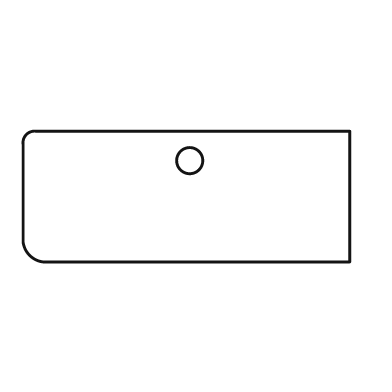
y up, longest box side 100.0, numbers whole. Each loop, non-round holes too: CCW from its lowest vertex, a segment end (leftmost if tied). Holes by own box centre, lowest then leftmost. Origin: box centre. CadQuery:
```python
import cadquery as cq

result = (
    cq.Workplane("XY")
    .moveTo(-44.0, -20.0)
    .lineTo(50.0, -20.0)
    .lineTo(50.0, 20.0)
    .lineTo(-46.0, 20.0)
    .threePointArc((-49.0, 19.0), (-50.0, 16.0))
    .lineTo(-50.0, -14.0)
    .threePointArc((-48.0, -18.0), (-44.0, -20.0))
    .close()
    .moveTo(1.0, 11.0)
    .circle(4.0)
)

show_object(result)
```